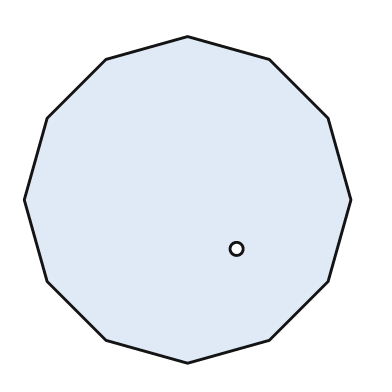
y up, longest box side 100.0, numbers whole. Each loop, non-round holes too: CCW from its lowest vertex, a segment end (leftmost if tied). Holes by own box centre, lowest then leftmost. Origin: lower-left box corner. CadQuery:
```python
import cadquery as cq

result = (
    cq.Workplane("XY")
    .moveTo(50.0, 0.0)
    .lineTo(75.0, 7.0)
    .lineTo(93.0, 25.0)
    .lineTo(100.0, 50.0)
    .lineTo(93.0, 75.0)
    .lineTo(75.0, 93.0)
    .lineTo(50.0, 100.0)
    .lineTo(25.0, 93.0)
    .lineTo(7.0, 75.0)
    .lineTo(0.0, 50.0)
    .lineTo(7.0, 25.0)
    .lineTo(25.0, 7.0)
    .close()
    .moveTo(65.0, 35.0)
    .circle(2.0)
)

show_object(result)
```